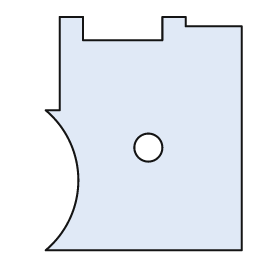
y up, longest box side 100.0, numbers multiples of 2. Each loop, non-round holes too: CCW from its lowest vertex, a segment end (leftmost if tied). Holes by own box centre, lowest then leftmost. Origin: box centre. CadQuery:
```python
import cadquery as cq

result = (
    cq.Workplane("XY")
    .moveTo(-42.0, -50.0)
    .lineTo(42.0, -50.0)
    .lineTo(42.0, 46.0)
    .lineTo(18.0, 46.0)
    .lineTo(18.0, 50.0)
    .lineTo(8.0, 50.0)
    .lineTo(8.0, 40.0)
    .lineTo(-26.0, 40.0)
    .lineTo(-26.0, 50.0)
    .lineTo(-36.0, 50.0)
    .lineTo(-36.0, 10.0)
    .lineTo(-42.0, 10.0)
    .threePointArc((-28.0, -20.0), (-42.0, -50.0))
    .close()
    .moveTo(2.0, -6.0)
    .circle(6.0)
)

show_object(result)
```